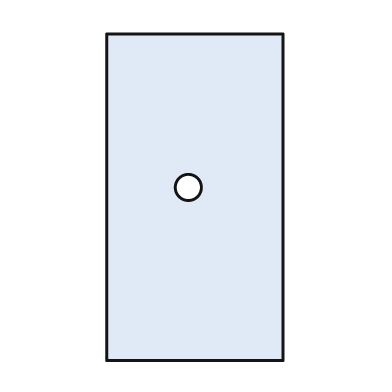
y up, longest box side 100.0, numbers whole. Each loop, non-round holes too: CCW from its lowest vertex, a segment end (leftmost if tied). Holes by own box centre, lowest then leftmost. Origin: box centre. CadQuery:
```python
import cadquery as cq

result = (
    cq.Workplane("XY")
    .moveTo(-27.0, -50.0)
    .lineTo(27.0, -50.0)
    .lineTo(27.0, 50.0)
    .lineTo(-27.0, 50.0)
    .close()
    .moveTo(-2.0, 3.0)
    .circle(4.0)
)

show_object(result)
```